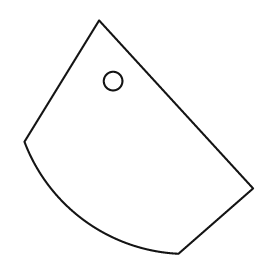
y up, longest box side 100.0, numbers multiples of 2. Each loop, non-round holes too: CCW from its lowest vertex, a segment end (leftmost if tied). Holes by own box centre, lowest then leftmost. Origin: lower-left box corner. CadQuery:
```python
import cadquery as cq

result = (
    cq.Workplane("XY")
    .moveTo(66.0, 0.0)
    .lineTo(98.0, 28.0)
    .lineTo(32.0, 100.0)
    .lineTo(0.0, 48.0)
    .threePointArc((26.0, 14.0), (66.0, 0.0))
    .close()
    .moveTo(38.0, 74.0)
    .circle(4.0)
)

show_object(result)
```